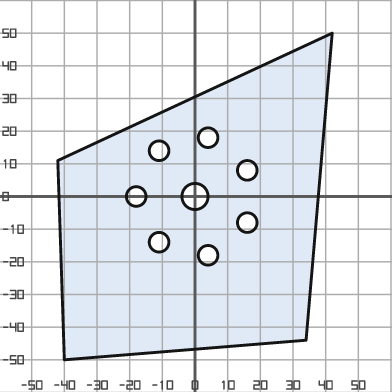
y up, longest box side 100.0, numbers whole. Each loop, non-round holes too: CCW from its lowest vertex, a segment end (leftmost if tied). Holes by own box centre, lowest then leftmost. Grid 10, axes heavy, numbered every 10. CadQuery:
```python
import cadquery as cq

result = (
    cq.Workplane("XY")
    .moveTo(-40.0, -50.0)
    .lineTo(34.0, -44.0)
    .lineTo(42.0, 50.0)
    .lineTo(-42.0, 11.0)
    .close()
    .moveTo(4.0, -18.0)
    .circle(3.0)
    .moveTo(-11.0, -14.0)
    .circle(3.0)
    .moveTo(16.0, -8.0)
    .circle(3.0)
    .moveTo(-18.0, 0.0)
    .circle(3.0)
    .moveTo(0.0, 0.0)
    .circle(4.0)
    .moveTo(16.0, 8.0)
    .circle(3.0)
    .moveTo(-11.0, 14.0)
    .circle(3.0)
    .moveTo(4.0, 18.0)
    .circle(3.0)
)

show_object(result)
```